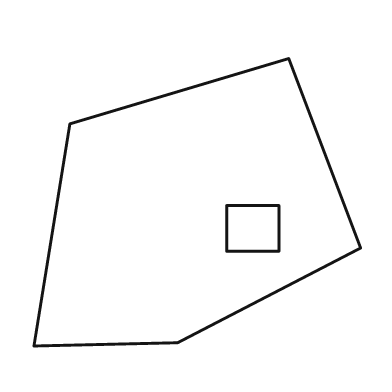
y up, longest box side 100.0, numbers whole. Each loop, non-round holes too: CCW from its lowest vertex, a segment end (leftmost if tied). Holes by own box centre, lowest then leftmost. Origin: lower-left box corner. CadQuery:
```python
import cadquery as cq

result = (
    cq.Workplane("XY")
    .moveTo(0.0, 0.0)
    .lineTo(44.0, 1.0)
    .lineTo(100.0, 30.0)
    .lineTo(78.0, 88.0)
    .lineTo(11.0, 68.0)
    .close()
    .moveTo(59.0, 29.0)
    .lineTo(75.0, 29.0)
    .lineTo(75.0, 43.0)
    .lineTo(59.0, 43.0)
    .close()
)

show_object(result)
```